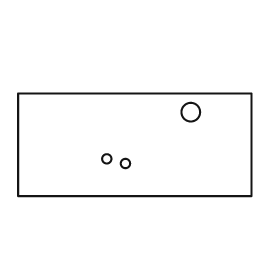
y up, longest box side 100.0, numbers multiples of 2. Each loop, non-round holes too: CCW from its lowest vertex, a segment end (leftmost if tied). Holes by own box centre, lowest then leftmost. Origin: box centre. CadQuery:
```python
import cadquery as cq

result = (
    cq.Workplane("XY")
    .moveTo(-50.0, -22.0)
    .lineTo(50.0, -22.0)
    .lineTo(50.0, 22.0)
    .lineTo(-50.0, 22.0)
    .close()
    .moveTo(-4.0, -8.0)
    .circle(2.0)
    .moveTo(-12.0, -6.0)
    .circle(2.0)
    .moveTo(24.0, 14.0)
    .circle(4.0)
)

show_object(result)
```